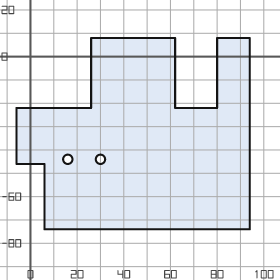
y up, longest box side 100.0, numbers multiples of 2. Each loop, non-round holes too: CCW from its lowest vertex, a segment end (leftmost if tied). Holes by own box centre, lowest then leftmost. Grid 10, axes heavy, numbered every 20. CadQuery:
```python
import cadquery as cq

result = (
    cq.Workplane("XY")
    .moveTo(6.0, -74.0)
    .lineTo(94.0, -74.0)
    .lineTo(94.0, 8.0)
    .lineTo(80.0, 8.0)
    .lineTo(80.0, -22.0)
    .lineTo(62.0, -22.0)
    .lineTo(62.0, 8.0)
    .lineTo(26.0, 8.0)
    .lineTo(26.0, -22.0)
    .lineTo(-6.0, -22.0)
    .lineTo(-6.0, -46.0)
    .lineTo(6.0, -46.0)
    .close()
    .moveTo(16.0, -44.0)
    .circle(2.0)
    .moveTo(30.0, -44.0)
    .circle(2.0)
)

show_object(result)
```